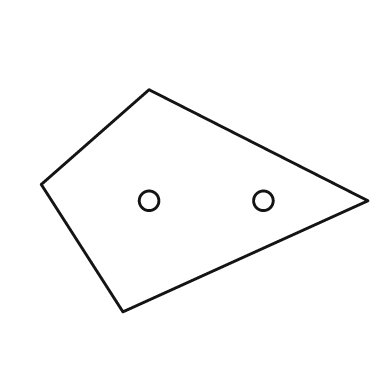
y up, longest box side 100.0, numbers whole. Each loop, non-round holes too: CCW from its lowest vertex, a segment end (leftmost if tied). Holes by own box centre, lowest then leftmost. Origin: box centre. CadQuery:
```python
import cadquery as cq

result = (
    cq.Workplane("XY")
    .moveTo(-25.0, -34.0)
    .lineTo(50.0, 0.0)
    .lineTo(-17.0, 34.0)
    .lineTo(-50.0, 5.0)
    .close()
    .moveTo(-17.0, 0.0)
    .circle(3.0)
    .moveTo(18.0, 0.0)
    .circle(3.0)
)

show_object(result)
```